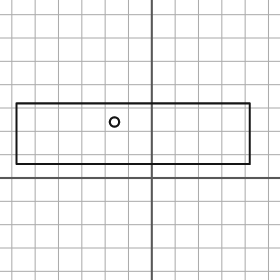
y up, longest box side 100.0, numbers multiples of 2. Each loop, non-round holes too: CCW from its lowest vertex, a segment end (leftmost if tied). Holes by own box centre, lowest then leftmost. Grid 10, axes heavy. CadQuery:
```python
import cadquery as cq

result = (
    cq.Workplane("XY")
    .moveTo(-58.0, 6.0)
    .lineTo(42.0, 6.0)
    .lineTo(42.0, 32.0)
    .lineTo(-58.0, 32.0)
    .close()
    .moveTo(-16.0, 24.0)
    .circle(2.0)
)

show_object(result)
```